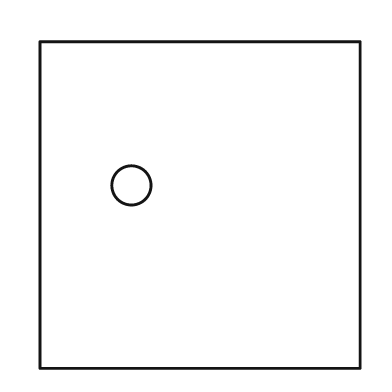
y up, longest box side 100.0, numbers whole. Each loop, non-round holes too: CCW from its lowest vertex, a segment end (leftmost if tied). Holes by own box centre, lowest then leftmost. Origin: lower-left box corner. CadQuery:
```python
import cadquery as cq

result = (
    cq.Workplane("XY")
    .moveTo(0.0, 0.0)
    .lineTo(98.0, 0.0)
    .lineTo(98.0, 100.0)
    .lineTo(0.0, 100.0)
    .close()
    .moveTo(28.0, 56.0)
    .circle(6.0)
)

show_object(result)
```